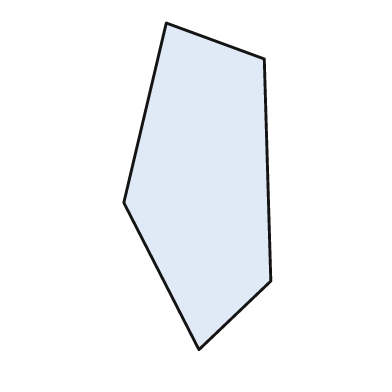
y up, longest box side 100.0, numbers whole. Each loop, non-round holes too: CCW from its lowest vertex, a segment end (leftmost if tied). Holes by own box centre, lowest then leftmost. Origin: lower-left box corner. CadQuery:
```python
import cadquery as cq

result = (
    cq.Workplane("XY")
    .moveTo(23.0, 0.0)
    .lineTo(45.0, 21.0)
    .lineTo(43.0, 89.0)
    .lineTo(13.0, 100.0)
    .lineTo(0.0, 45.0)
    .close()
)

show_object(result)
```